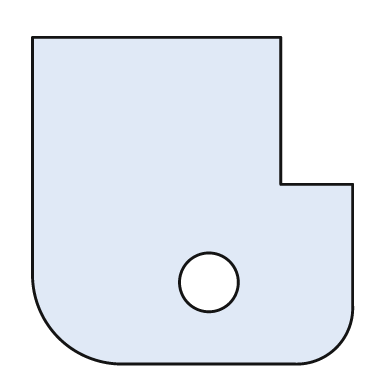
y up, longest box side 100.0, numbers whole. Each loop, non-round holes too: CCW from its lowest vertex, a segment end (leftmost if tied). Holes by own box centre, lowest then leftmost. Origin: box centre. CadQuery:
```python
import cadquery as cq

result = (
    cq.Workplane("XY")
    .moveTo(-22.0, -50.0)
    .lineTo(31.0, -50.0)
    .threePointArc((44.0, -45.0), (49.0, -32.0))
    .lineTo(49.0, 5.0)
    .lineTo(27.0, 5.0)
    .lineTo(27.0, 50.0)
    .lineTo(-49.0, 50.0)
    .lineTo(-49.0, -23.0)
    .threePointArc((-41.0, -42.0), (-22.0, -50.0))
    .close()
    .moveTo(5.0, -25.0)
    .circle(9.0)
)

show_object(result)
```